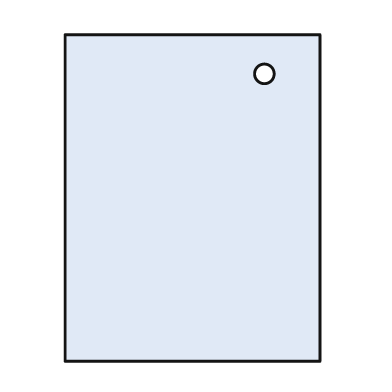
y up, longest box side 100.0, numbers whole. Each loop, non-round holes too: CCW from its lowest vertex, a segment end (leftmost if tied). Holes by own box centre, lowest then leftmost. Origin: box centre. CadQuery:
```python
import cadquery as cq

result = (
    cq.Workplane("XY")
    .moveTo(-39.0, -50.0)
    .lineTo(39.0, -50.0)
    .lineTo(39.0, 50.0)
    .lineTo(-39.0, 50.0)
    .close()
    .moveTo(22.0, 38.0)
    .circle(3.0)
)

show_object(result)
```